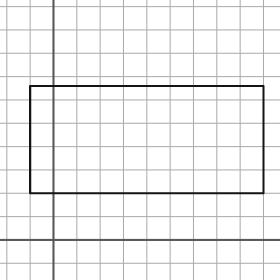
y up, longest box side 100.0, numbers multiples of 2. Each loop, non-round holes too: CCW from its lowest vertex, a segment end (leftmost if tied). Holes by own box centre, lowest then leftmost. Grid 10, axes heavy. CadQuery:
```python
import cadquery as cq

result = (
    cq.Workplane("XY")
    .moveTo(-10.0, 20.0)
    .lineTo(90.0, 20.0)
    .lineTo(90.0, 66.0)
    .lineTo(-10.0, 66.0)
    .close()
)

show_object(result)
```